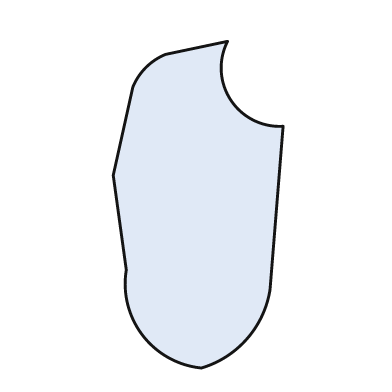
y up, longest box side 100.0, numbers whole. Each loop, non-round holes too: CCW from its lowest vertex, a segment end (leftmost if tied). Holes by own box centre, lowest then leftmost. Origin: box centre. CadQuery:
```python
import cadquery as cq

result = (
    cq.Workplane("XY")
    .moveTo(1.0, -50.0)
    .threePointArc((15.0, -41.0), (22.0, -26.0))
    .lineTo(26.0, 24.0)
    .threePointArc((10.0, 32.0), (9.0, 50.0))
    .lineTo(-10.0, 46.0)
    .threePointArc((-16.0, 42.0), (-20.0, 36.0))
    .lineTo(-26.0, 9.0)
    .lineTo(-22.0, -20.0)
    .threePointArc((-17.0, -40.0), (1.0, -50.0))
    .close()
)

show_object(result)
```